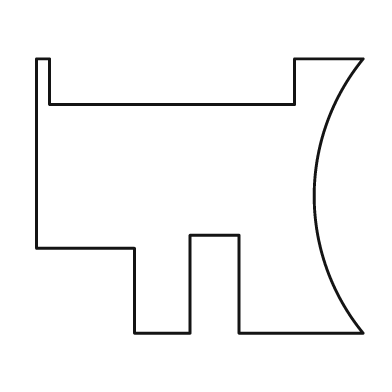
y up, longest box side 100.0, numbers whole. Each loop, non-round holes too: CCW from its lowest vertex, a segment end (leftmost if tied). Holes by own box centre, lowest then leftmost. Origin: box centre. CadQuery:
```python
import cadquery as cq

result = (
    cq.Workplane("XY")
    .moveTo(-20.0, -42.0)
    .lineTo(-3.0, -42.0)
    .lineTo(-3.0, -12.0)
    .lineTo(12.0, -12.0)
    .lineTo(12.0, -42.0)
    .lineTo(50.0, -42.0)
    .threePointArc((35.0, 0.0), (50.0, 42.0))
    .lineTo(29.0, 42.0)
    .lineTo(29.0, 28.0)
    .lineTo(-46.0, 28.0)
    .lineTo(-46.0, 42.0)
    .lineTo(-50.0, 42.0)
    .lineTo(-50.0, -16.0)
    .lineTo(-20.0, -16.0)
    .close()
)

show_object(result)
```